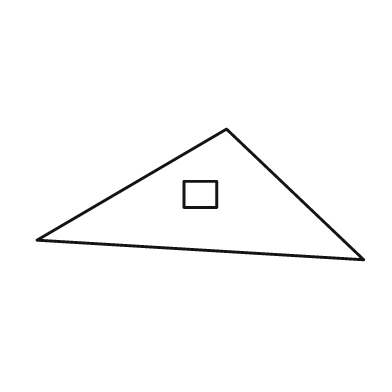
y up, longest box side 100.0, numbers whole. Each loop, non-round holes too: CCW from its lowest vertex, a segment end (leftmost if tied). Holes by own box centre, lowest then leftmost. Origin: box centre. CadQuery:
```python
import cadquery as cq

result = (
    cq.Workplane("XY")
    .moveTo(50.0, -20.0)
    .lineTo(8.0, 20.0)
    .lineTo(-50.0, -14.0)
    .close()
    .moveTo(-5.0, -4.0)
    .lineTo(5.0, -4.0)
    .lineTo(5.0, 4.0)
    .lineTo(-5.0, 4.0)
    .close()
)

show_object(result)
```